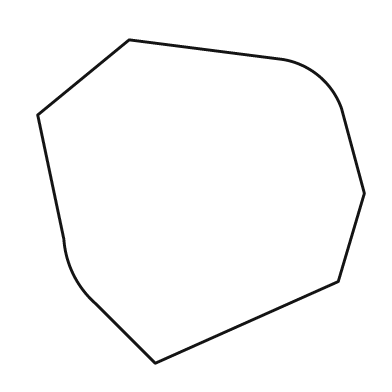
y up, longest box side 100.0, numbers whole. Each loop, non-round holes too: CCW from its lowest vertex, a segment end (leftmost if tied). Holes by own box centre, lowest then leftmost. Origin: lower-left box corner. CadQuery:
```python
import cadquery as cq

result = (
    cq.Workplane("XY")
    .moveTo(36.0, 0.0)
    .lineTo(92.0, 25.0)
    .lineTo(100.0, 52.0)
    .lineTo(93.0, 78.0)
    .threePointArc((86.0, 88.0), (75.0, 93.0))
    .lineTo(28.0, 99.0)
    .lineTo(0.0, 76.0)
    .lineTo(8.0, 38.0)
    .threePointArc((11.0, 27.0), (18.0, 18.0))
    .close()
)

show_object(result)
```